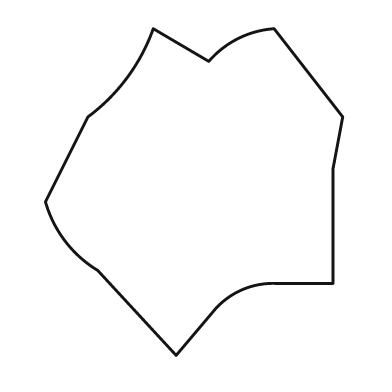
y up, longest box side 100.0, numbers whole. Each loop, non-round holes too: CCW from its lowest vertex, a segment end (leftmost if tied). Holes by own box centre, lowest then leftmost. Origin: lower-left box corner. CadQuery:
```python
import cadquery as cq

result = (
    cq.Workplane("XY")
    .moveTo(40.0, 0.0)
    .lineTo(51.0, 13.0)
    .threePointArc((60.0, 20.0), (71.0, 22.0))
    .lineTo(88.0, 22.0)
    .lineTo(88.0, 57.0)
    .lineTo(91.0, 73.0)
    .lineTo(70.0, 100.0)
    .threePointArc((59.0, 97.0), (50.0, 90.0))
    .lineTo(33.0, 100.0)
    .threePointArc((25.0, 85.0), (13.0, 73.0))
    .lineTo(0.0, 47.0)
    .threePointArc((6.0, 35.0), (16.0, 26.0))
    .close()
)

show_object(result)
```